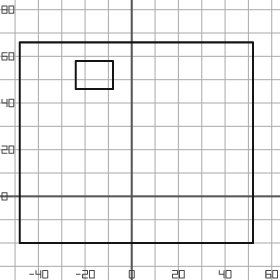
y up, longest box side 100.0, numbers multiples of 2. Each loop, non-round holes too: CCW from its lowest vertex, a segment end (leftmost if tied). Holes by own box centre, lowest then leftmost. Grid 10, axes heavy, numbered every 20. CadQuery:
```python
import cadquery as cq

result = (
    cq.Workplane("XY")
    .moveTo(-48.0, -20.0)
    .lineTo(52.0, -20.0)
    .lineTo(52.0, 66.0)
    .lineTo(-48.0, 66.0)
    .close()
    .moveTo(-24.0, 46.0)
    .lineTo(-8.0, 46.0)
    .lineTo(-8.0, 58.0)
    .lineTo(-24.0, 58.0)
    .close()
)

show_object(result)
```